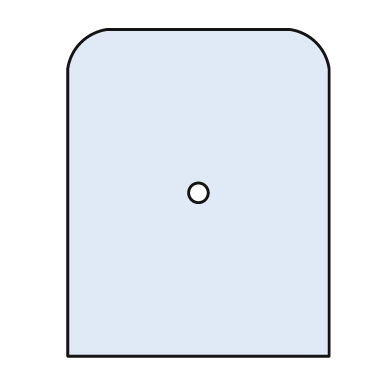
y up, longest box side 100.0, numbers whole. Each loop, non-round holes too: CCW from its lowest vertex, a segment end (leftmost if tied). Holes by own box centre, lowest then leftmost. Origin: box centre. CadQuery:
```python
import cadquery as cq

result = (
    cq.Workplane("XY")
    .moveTo(-40.0, -50.0)
    .lineTo(40.0, -50.0)
    .lineTo(40.0, 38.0)
    .threePointArc((36.0, 46.0), (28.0, 50.0))
    .lineTo(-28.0, 50.0)
    .threePointArc((-36.0, 46.0), (-40.0, 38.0))
    .close()
    .moveTo(0.0, 0.0)
    .circle(3.0)
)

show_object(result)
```